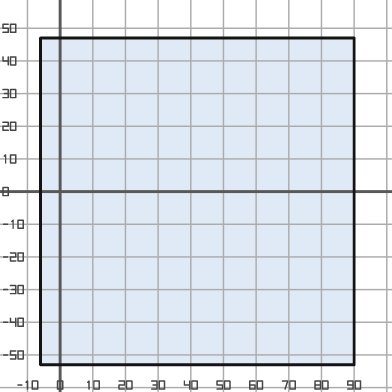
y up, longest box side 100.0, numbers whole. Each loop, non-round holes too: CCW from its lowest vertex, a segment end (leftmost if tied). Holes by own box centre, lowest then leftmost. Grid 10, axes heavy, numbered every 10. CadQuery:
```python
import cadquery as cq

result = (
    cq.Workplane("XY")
    .moveTo(-6.0, -53.0)
    .lineTo(90.0, -53.0)
    .lineTo(90.0, 47.0)
    .lineTo(-6.0, 47.0)
    .close()
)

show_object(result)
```